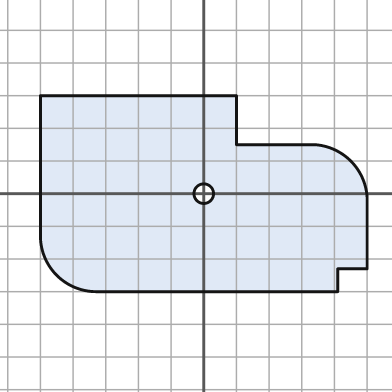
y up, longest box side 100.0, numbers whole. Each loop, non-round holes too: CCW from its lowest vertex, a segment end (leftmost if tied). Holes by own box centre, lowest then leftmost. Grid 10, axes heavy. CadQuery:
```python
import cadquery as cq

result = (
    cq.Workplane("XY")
    .moveTo(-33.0, -30.0)
    .lineTo(41.0, -30.0)
    .lineTo(41.0, -23.0)
    .lineTo(50.0, -23.0)
    .lineTo(50.0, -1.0)
    .threePointArc((45.0, 10.0), (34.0, 15.0))
    .lineTo(10.0, 15.0)
    .lineTo(10.0, 30.0)
    .lineTo(-50.0, 30.0)
    .lineTo(-50.0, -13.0)
    .threePointArc((-45.0, -25.0), (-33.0, -30.0))
    .close()
    .moveTo(0.0, 0.0)
    .circle(3.0)
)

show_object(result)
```